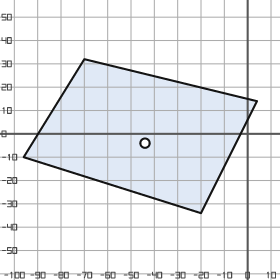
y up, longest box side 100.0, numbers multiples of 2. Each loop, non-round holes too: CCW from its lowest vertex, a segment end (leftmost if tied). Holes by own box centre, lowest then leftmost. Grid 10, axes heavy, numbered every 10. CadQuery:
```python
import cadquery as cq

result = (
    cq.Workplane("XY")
    .moveTo(-20.0, -34.0)
    .lineTo(4.0, 14.0)
    .lineTo(-70.0, 32.0)
    .lineTo(-96.0, -10.0)
    .close()
    .moveTo(-44.0, -4.0)
    .circle(2.0)
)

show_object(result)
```